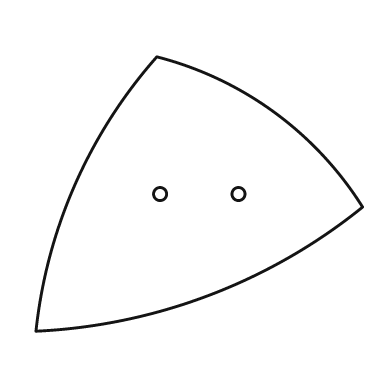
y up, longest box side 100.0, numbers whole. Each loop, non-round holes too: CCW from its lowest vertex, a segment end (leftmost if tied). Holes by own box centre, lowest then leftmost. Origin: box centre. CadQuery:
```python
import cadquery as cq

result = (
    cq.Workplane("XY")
    .moveTo(-50.0, -42.0)
    .threePointArc((3.0, -31.0), (50.0, -4.0))
    .threePointArc((23.0, 25.0), (-13.0, 42.0))
    .threePointArc((-38.0, 3.0), (-50.0, -42.0))
    .close()
    .moveTo(-12.0, 0.0)
    .circle(2.0)
    .moveTo(12.0, 0.0)
    .circle(2.0)
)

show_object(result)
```